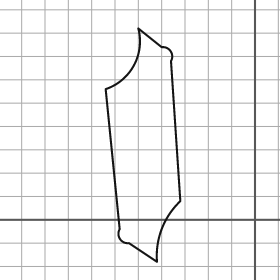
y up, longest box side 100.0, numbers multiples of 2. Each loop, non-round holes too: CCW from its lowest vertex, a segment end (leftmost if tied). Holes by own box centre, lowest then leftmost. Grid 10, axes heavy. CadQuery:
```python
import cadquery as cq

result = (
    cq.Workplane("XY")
    .moveTo(-42.0, -18.0)
    .threePointArc((-40.0, -4.0), (-32.0, 8.0))
    .lineTo(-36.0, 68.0)
    .threePointArc((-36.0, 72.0), (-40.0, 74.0))
    .lineTo(-50.0, 82.0)
    .threePointArc((-52.0, 66.0), (-64.0, 56.0))
    .lineTo(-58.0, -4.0)
    .threePointArc((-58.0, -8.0), (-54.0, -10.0))
    .close()
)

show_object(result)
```